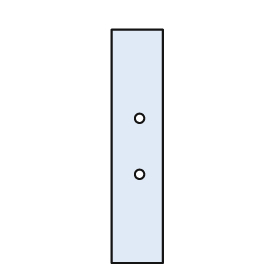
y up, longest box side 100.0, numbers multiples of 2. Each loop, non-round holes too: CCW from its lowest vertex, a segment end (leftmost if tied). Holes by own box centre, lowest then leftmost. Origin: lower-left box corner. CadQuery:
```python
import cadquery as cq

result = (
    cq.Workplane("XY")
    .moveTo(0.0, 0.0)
    .lineTo(22.0, 0.0)
    .lineTo(22.0, 100.0)
    .lineTo(0.0, 100.0)
    .close()
    .moveTo(12.0, 38.0)
    .circle(2.0)
    .moveTo(12.0, 62.0)
    .circle(2.0)
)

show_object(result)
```